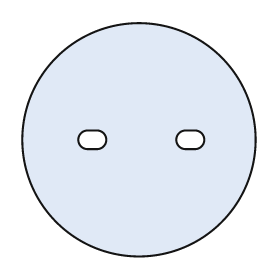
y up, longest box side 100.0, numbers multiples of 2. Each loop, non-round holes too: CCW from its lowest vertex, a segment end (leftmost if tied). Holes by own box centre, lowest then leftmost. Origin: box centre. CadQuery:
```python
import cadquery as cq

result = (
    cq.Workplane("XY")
    .moveTo(0.0, 0.0)
    .circle(50.0)
    .moveTo(-22.0, -4.0)
    .lineTo(-18.0, -4.0)
    .threePointArc((-14.0, 0.0), (-18.0, 4.0))
    .lineTo(-22.0, 4.0)
    .threePointArc((-26.0, 0.0), (-22.0, -4.0))
    .close()
    .moveTo(20.0, -4.0)
    .lineTo(24.0, -4.0)
    .threePointArc((28.0, 0.0), (24.0, 4.0))
    .lineTo(20.0, 4.0)
    .threePointArc((16.0, 0.0), (20.0, -4.0))
    .close()
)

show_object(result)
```